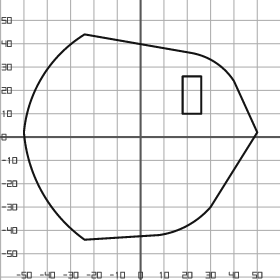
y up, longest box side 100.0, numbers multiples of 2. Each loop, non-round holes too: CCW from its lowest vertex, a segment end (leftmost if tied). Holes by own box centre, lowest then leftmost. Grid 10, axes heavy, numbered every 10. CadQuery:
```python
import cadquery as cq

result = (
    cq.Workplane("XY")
    .moveTo(-24.0, -44.0)
    .lineTo(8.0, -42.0)
    .threePointArc((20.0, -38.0), (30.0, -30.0))
    .lineTo(50.0, 2.0)
    .lineTo(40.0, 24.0)
    .threePointArc((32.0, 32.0), (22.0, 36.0))
    .lineTo(-24.0, 44.0)
    .threePointArc((-42.0, 26.0), (-50.0, 2.0))
    .threePointArc((-42.0, -24.0), (-24.0, -44.0))
    .close()
    .moveTo(18.0, 10.0)
    .lineTo(26.0, 10.0)
    .lineTo(26.0, 26.0)
    .lineTo(18.0, 26.0)
    .close()
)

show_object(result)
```